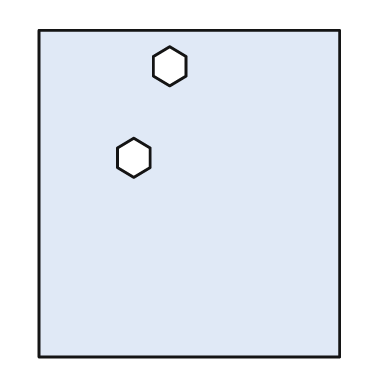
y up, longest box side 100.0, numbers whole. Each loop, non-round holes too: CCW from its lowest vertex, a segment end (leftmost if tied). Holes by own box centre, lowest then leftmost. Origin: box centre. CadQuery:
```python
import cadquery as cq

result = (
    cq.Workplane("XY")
    .moveTo(-46.0, -50.0)
    .lineTo(46.0, -50.0)
    .lineTo(46.0, 50.0)
    .lineTo(-46.0, 50.0)
    .close()
    .moveTo(-17.0, 5.0)
    .lineTo(-12.0, 8.0)
    .lineTo(-12.0, 14.0)
    .lineTo(-17.0, 17.0)
    .lineTo(-22.0, 14.0)
    .lineTo(-22.0, 8.0)
    .close()
    .moveTo(-6.0, 33.0)
    .lineTo(-1.0, 36.0)
    .lineTo(-1.0, 42.0)
    .lineTo(-6.0, 45.0)
    .lineTo(-11.0, 42.0)
    .lineTo(-11.0, 36.0)
    .close()
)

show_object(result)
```